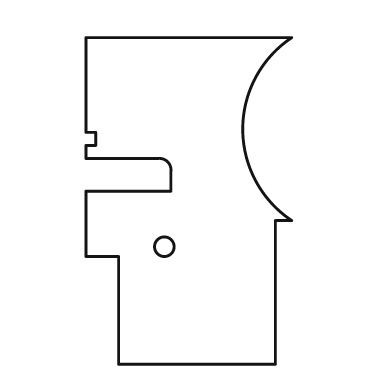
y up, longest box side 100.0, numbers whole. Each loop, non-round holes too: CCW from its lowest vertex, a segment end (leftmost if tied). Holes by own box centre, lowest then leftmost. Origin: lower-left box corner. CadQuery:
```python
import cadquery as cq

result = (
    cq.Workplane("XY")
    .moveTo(10.0, 0.0)
    .lineTo(58.0, 0.0)
    .lineTo(58.0, 44.0)
    .lineTo(63.0, 44.0)
    .threePointArc((48.0, 72.0), (63.0, 100.0))
    .lineTo(0.0, 100.0)
    .lineTo(0.0, 71.0)
    .lineTo(3.0, 71.0)
    .lineTo(3.0, 67.0)
    .lineTo(0.0, 67.0)
    .lineTo(0.0, 63.0)
    .lineTo(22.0, 63.0)
    .threePointArc((25.0, 62.0), (26.0, 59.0))
    .lineTo(26.0, 53.0)
    .lineTo(0.0, 53.0)
    .lineTo(0.0, 33.0)
    .lineTo(10.0, 33.0)
    .close()
    .moveTo(24.0, 36.0)
    .circle(3.0)
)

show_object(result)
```